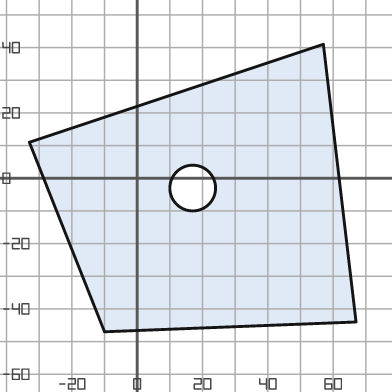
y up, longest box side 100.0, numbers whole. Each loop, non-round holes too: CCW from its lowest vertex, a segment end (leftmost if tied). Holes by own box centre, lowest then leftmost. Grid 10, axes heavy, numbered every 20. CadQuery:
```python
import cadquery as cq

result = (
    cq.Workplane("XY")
    .moveTo(-10.0, -47.0)
    .lineTo(67.0, -44.0)
    .lineTo(57.0, 41.0)
    .lineTo(-33.0, 11.0)
    .close()
    .moveTo(17.0, -3.0)
    .circle(7.0)
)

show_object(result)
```